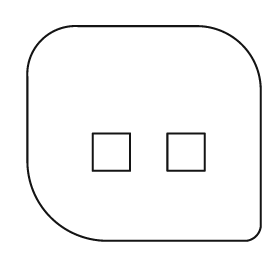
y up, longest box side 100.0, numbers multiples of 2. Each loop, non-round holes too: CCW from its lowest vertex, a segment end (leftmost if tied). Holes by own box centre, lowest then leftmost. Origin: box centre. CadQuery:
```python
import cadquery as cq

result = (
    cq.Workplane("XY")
    .moveTo(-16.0, -46.0)
    .lineTo(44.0, -46.0)
    .threePointArc((48.0, -44.0), (50.0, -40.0))
    .lineTo(50.0, 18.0)
    .threePointArc((42.0, 38.0), (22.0, 46.0))
    .lineTo(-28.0, 46.0)
    .threePointArc((-44.0, 40.0), (-50.0, 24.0))
    .lineTo(-50.0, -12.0)
    .threePointArc((-40.0, -36.0), (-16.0, -46.0))
    .close()
    .moveTo(-22.0, -16.0)
    .lineTo(-6.0, -16.0)
    .lineTo(-6.0, 0.0)
    .lineTo(-22.0, 0.0)
    .close()
    .moveTo(10.0, -16.0)
    .lineTo(26.0, -16.0)
    .lineTo(26.0, 0.0)
    .lineTo(10.0, 0.0)
    .close()
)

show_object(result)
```